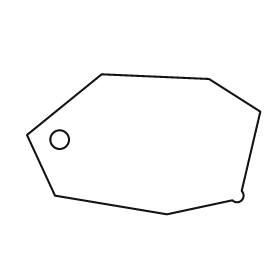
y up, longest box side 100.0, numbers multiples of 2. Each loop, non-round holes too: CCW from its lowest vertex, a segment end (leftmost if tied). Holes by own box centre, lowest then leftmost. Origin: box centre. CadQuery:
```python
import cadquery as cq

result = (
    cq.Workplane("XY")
    .moveTo(10.0, -30.0)
    .lineTo(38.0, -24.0)
    .threePointArc((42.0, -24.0), (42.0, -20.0))
    .lineTo(50.0, 14.0)
    .lineTo(28.0, 28.0)
    .lineTo(-18.0, 30.0)
    .lineTo(-50.0, 4.0)
    .lineTo(-38.0, -22.0)
    .close()
    .moveTo(-36.0, 2.0)
    .circle(4.0)
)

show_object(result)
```